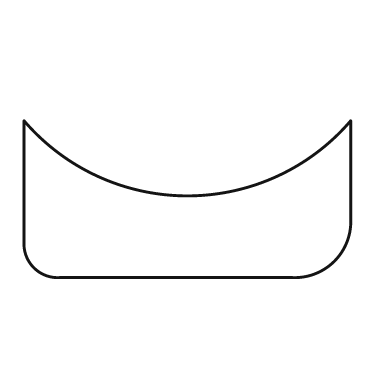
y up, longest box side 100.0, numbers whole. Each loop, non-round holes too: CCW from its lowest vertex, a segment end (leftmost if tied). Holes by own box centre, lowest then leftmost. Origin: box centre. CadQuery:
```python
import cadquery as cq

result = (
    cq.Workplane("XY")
    .moveTo(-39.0, -24.0)
    .lineTo(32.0, -24.0)
    .threePointArc((45.0, -19.0), (50.0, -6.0))
    .lineTo(50.0, 24.0)
    .threePointArc((0.0, 1.0), (-50.0, 24.0))
    .lineTo(-50.0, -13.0)
    .threePointArc((-47.0, -21.0), (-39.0, -24.0))
    .close()
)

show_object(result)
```